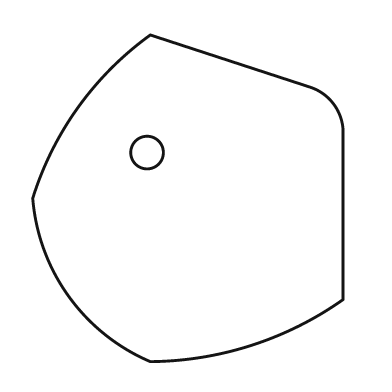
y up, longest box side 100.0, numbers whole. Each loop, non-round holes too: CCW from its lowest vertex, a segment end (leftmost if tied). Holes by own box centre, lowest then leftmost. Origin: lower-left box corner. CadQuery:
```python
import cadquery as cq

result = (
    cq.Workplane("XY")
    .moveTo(36.0, 0.0)
    .threePointArc((67.0, 5.0), (95.0, 19.0))
    .lineTo(95.0, 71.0)
    .threePointArc((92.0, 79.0), (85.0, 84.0))
    .lineTo(36.0, 100.0)
    .threePointArc((14.0, 78.0), (0.0, 50.0))
    .threePointArc((11.0, 20.0), (36.0, 0.0))
    .close()
    .moveTo(35.0, 64.0)
    .circle(5.0)
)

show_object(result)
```